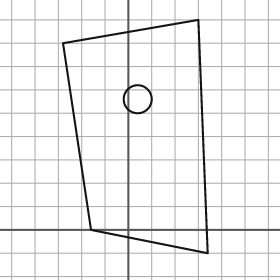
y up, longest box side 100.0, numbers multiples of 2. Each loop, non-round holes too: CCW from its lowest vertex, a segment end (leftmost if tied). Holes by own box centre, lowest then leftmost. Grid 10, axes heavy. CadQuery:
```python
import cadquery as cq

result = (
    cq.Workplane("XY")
    .moveTo(34.0, -10.0)
    .lineTo(30.0, 90.0)
    .lineTo(-28.0, 80.0)
    .lineTo(-16.0, 0.0)
    .close()
    .moveTo(4.0, 56.0)
    .circle(6.0)
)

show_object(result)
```